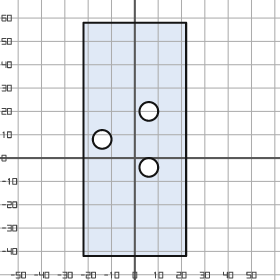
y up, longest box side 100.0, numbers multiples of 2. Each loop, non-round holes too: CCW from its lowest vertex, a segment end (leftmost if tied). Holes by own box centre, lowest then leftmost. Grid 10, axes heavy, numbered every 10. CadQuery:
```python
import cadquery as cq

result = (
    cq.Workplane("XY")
    .moveTo(-22.0, -42.0)
    .lineTo(22.0, -42.0)
    .lineTo(22.0, 58.0)
    .lineTo(-22.0, 58.0)
    .close()
    .moveTo(6.0, -4.0)
    .circle(4.0)
    .moveTo(-14.0, 8.0)
    .circle(4.0)
    .moveTo(6.0, 20.0)
    .circle(4.0)
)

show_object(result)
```